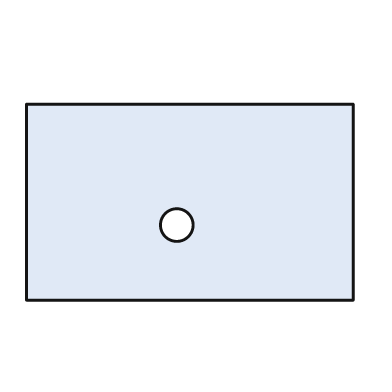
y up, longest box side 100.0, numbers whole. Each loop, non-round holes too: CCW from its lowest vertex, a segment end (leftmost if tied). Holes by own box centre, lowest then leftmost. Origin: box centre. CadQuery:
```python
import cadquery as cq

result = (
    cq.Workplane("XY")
    .moveTo(-50.0, -30.0)
    .lineTo(50.0, -30.0)
    .lineTo(50.0, 30.0)
    .lineTo(-50.0, 30.0)
    .close()
    .moveTo(-4.0, -7.0)
    .circle(5.0)
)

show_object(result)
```